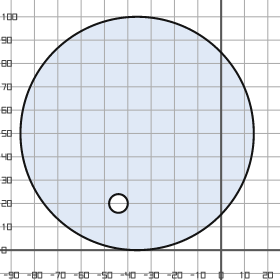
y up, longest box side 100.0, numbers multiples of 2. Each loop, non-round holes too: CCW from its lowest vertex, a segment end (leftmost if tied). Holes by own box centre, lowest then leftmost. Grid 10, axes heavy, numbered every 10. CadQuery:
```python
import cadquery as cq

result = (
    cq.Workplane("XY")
    .moveTo(-36.0, 50.0)
    .circle(50.0)
    .moveTo(-44.0, 20.0)
    .circle(4.0)
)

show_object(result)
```